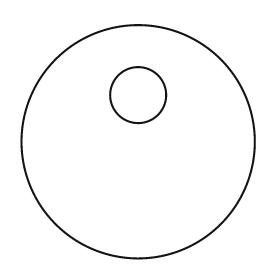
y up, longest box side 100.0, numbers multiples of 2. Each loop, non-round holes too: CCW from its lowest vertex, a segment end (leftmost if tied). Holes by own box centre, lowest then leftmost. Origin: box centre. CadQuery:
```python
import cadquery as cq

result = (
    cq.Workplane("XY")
    .moveTo(0.0, 0.0)
    .circle(50.0)
    .moveTo(0.0, 20.0)
    .circle(12.0)
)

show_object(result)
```